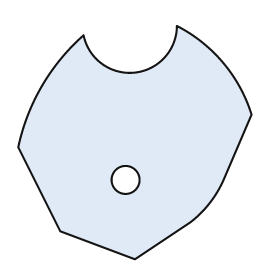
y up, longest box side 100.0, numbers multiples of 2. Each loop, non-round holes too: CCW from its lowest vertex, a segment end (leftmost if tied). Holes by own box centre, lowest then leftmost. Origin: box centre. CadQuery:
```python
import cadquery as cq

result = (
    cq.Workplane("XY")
    .moveTo(0.0, -50.0)
    .lineTo(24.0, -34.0)
    .threePointArc((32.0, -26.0), (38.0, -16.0))
    .lineTo(50.0, 12.0)
    .threePointArc((38.0, 34.0), (18.0, 50.0))
    .threePointArc((0.0, 30.0), (-22.0, 46.0))
    .threePointArc((-40.0, 24.0), (-50.0, -2.0))
    .lineTo(-32.0, -38.0)
    .close()
    .moveTo(-4.0, -16.0)
    .circle(6.0)
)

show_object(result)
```